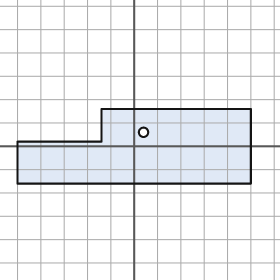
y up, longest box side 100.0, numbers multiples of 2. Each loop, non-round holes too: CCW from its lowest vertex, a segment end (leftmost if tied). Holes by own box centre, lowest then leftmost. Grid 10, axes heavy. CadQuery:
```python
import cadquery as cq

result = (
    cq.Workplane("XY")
    .moveTo(-50.0, -16.0)
    .lineTo(50.0, -16.0)
    .lineTo(50.0, 16.0)
    .lineTo(-14.0, 16.0)
    .lineTo(-14.0, 2.0)
    .lineTo(-50.0, 2.0)
    .close()
    .moveTo(4.0, 6.0)
    .circle(2.0)
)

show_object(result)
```